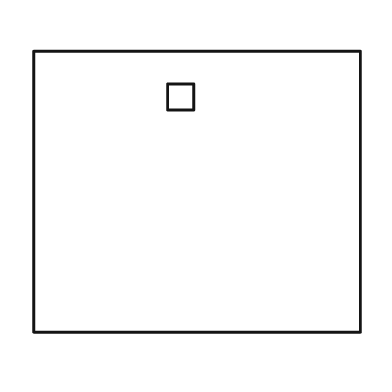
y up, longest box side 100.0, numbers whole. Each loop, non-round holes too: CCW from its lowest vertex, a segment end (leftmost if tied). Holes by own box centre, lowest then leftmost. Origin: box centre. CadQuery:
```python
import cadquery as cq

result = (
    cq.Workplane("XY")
    .moveTo(-50.0, -43.0)
    .lineTo(50.0, -43.0)
    .lineTo(50.0, 43.0)
    .lineTo(-50.0, 43.0)
    .close()
    .moveTo(-9.0, 25.0)
    .lineTo(-1.0, 25.0)
    .lineTo(-1.0, 33.0)
    .lineTo(-9.0, 33.0)
    .close()
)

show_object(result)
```